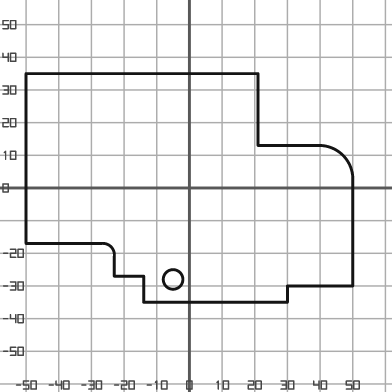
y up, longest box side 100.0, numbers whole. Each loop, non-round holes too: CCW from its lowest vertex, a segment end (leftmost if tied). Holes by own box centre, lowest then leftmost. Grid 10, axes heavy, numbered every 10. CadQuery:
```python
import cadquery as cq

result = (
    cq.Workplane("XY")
    .moveTo(-14.0, -35.0)
    .lineTo(30.0, -35.0)
    .lineTo(30.0, -30.0)
    .lineTo(50.0, -30.0)
    .lineTo(50.0, 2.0)
    .threePointArc((47.0, 10.0), (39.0, 13.0))
    .lineTo(21.0, 13.0)
    .lineTo(21.0, 35.0)
    .lineTo(-50.0, 35.0)
    .lineTo(-50.0, -17.0)
    .lineTo(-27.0, -17.0)
    .threePointArc((-24.0, -18.0), (-23.0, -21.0))
    .lineTo(-23.0, -27.0)
    .lineTo(-14.0, -27.0)
    .close()
    .moveTo(-5.0, -28.0)
    .circle(3.0)
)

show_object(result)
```